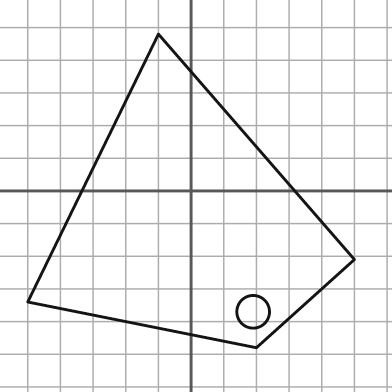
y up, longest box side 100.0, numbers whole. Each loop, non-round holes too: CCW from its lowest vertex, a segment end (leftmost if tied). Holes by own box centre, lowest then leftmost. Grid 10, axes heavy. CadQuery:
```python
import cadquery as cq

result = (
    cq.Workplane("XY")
    .moveTo(20.0, -48.0)
    .lineTo(50.0, -21.0)
    .lineTo(-10.0, 48.0)
    .lineTo(-50.0, -34.0)
    .close()
    .moveTo(19.0, -37.0)
    .circle(5.0)
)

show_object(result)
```